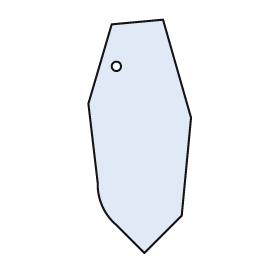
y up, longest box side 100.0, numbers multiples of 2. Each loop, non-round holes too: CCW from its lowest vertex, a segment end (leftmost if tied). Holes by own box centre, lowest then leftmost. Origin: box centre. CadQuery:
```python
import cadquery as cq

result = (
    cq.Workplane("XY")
    .moveTo(2.0, -50.0)
    .lineTo(18.0, -34.0)
    .lineTo(22.0, 8.0)
    .lineTo(10.0, 50.0)
    .lineTo(-12.0, 48.0)
    .lineTo(-22.0, 14.0)
    .lineTo(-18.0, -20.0)
    .threePointArc((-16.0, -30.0), (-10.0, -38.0))
    .close()
    .moveTo(-10.0, 30.0)
    .circle(2.0)
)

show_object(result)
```